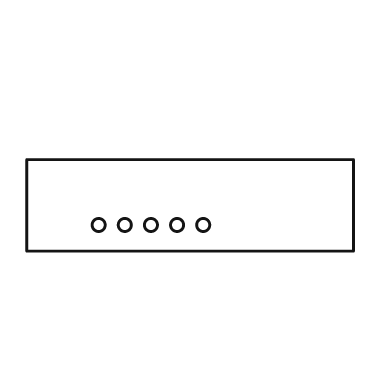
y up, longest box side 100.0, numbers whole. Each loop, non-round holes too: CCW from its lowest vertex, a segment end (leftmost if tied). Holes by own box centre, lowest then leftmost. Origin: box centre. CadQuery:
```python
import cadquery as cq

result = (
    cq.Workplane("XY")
    .moveTo(-50.0, -14.0)
    .lineTo(50.0, -14.0)
    .lineTo(50.0, 14.0)
    .lineTo(-50.0, 14.0)
    .close()
    .moveTo(-28.0, -6.0)
    .circle(2.0)
    .moveTo(-20.0, -6.0)
    .circle(2.0)
    .moveTo(-12.0, -6.0)
    .circle(2.0)
    .moveTo(-4.0, -6.0)
    .circle(2.0)
    .moveTo(4.0, -6.0)
    .circle(2.0)
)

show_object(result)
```